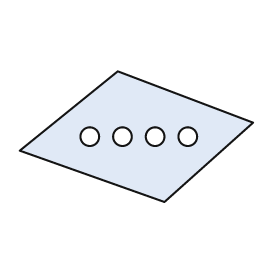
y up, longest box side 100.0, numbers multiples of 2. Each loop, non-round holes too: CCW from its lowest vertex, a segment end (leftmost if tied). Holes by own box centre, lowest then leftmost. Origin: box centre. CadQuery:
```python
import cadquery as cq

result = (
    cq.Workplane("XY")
    .moveTo(12.0, -28.0)
    .lineTo(50.0, 6.0)
    .lineTo(-8.0, 28.0)
    .lineTo(-50.0, -6.0)
    .close()
    .moveTo(-20.0, 0.0)
    .circle(4.0)
    .moveTo(-6.0, 0.0)
    .circle(4.0)
    .moveTo(8.0, 0.0)
    .circle(4.0)
    .moveTo(22.0, 0.0)
    .circle(4.0)
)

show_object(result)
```